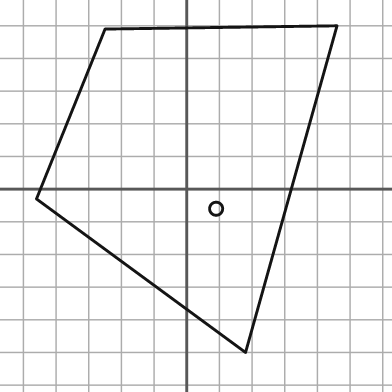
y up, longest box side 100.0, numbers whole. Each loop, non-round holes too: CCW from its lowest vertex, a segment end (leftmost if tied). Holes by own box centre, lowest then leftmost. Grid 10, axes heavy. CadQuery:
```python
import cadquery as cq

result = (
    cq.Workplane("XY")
    .moveTo(18.0, -50.0)
    .lineTo(46.0, 50.0)
    .lineTo(-25.0, 49.0)
    .lineTo(-46.0, -3.0)
    .close()
    .moveTo(9.0, -6.0)
    .circle(2.0)
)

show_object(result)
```